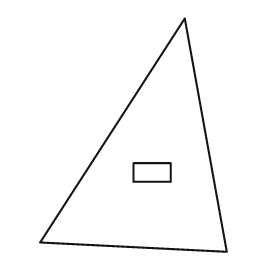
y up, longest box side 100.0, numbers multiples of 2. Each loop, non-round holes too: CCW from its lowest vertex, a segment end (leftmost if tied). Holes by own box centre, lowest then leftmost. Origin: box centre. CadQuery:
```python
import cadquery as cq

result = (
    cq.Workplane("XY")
    .moveTo(40.0, -50.0)
    .lineTo(22.0, 50.0)
    .lineTo(-40.0, -46.0)
    .close()
    .moveTo(0.0, -20.0)
    .lineTo(16.0, -20.0)
    .lineTo(16.0, -12.0)
    .lineTo(0.0, -12.0)
    .close()
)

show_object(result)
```